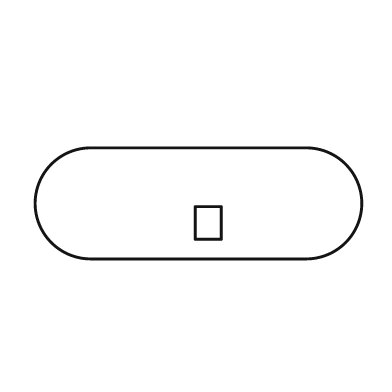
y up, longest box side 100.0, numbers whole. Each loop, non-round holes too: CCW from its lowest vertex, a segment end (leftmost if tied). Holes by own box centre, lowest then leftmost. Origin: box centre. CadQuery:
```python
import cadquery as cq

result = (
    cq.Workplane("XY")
    .moveTo(-33.0, -17.0)
    .lineTo(33.0, -17.0)
    .threePointArc((50.0, 0.0), (33.0, 17.0))
    .lineTo(-33.0, 17.0)
    .threePointArc((-50.0, 0.0), (-33.0, -17.0))
    .close()
    .moveTo(-1.0, -11.0)
    .lineTo(7.0, -11.0)
    .lineTo(7.0, -1.0)
    .lineTo(-1.0, -1.0)
    .close()
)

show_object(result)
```